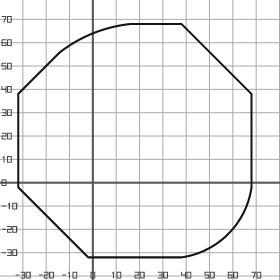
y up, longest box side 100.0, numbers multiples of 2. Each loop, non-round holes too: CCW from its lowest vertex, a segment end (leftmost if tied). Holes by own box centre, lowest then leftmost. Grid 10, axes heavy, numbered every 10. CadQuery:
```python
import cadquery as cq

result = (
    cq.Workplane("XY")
    .moveTo(-2.0, -32.0)
    .lineTo(38.0, -32.0)
    .threePointArc((58.0, -22.0), (68.0, -2.0))
    .lineTo(68.0, 38.0)
    .lineTo(38.0, 68.0)
    .lineTo(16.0, 68.0)
    .threePointArc((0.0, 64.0), (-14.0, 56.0))
    .lineTo(-32.0, 38.0)
    .lineTo(-32.0, -2.0)
    .close()
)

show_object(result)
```